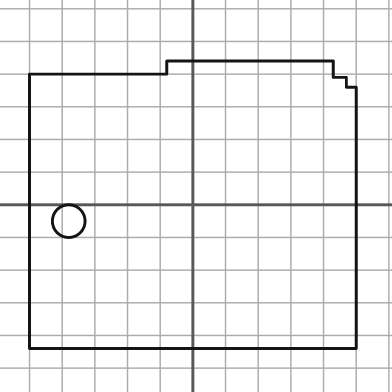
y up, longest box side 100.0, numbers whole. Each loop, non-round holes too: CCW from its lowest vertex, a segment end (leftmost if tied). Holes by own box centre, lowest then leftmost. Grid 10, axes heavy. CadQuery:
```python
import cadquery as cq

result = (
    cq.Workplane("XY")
    .moveTo(-50.0, -44.0)
    .lineTo(50.0, -44.0)
    .lineTo(50.0, 36.0)
    .lineTo(47.0, 36.0)
    .lineTo(47.0, 39.0)
    .lineTo(43.0, 39.0)
    .lineTo(43.0, 44.0)
    .lineTo(-8.0, 44.0)
    .lineTo(-8.0, 40.0)
    .lineTo(-50.0, 40.0)
    .close()
    .moveTo(-38.0, -5.0)
    .circle(5.0)
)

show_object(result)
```